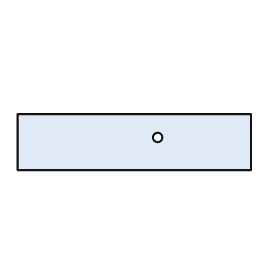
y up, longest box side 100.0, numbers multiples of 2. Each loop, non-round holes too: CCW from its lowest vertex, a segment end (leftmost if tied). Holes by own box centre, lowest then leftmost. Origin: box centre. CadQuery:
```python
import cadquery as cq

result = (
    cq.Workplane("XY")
    .moveTo(-50.0, -12.0)
    .lineTo(50.0, -12.0)
    .lineTo(50.0, 12.0)
    .lineTo(-50.0, 12.0)
    .close()
    .moveTo(10.0, 2.0)
    .circle(2.0)
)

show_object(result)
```